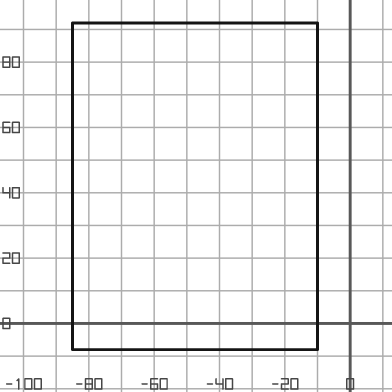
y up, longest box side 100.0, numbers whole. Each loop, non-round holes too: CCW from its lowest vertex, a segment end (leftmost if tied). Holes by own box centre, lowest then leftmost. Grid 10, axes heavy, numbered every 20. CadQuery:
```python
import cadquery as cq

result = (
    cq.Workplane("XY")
    .moveTo(-85.0, -8.0)
    .lineTo(-10.0, -8.0)
    .lineTo(-10.0, 92.0)
    .lineTo(-85.0, 92.0)
    .close()
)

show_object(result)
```